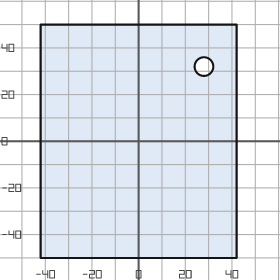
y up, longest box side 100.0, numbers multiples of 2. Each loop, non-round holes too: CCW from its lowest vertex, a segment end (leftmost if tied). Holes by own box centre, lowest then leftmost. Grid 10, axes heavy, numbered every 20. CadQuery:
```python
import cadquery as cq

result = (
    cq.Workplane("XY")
    .moveTo(-42.0, -50.0)
    .lineTo(42.0, -50.0)
    .lineTo(42.0, 50.0)
    .lineTo(-42.0, 50.0)
    .close()
    .moveTo(28.0, 32.0)
    .circle(4.0)
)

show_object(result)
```